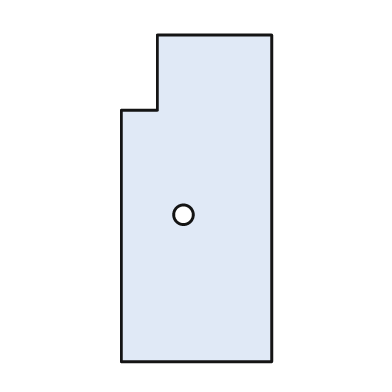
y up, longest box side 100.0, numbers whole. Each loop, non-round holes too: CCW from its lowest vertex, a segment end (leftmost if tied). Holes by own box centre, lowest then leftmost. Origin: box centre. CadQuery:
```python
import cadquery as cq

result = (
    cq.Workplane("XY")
    .moveTo(-23.0, -50.0)
    .lineTo(23.0, -50.0)
    .lineTo(23.0, 50.0)
    .lineTo(-12.0, 50.0)
    .lineTo(-12.0, 27.0)
    .lineTo(-23.0, 27.0)
    .close()
    .moveTo(-4.0, -5.0)
    .circle(3.0)
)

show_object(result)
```